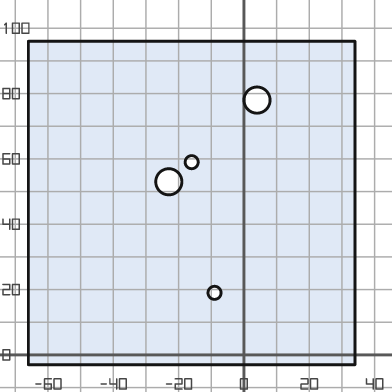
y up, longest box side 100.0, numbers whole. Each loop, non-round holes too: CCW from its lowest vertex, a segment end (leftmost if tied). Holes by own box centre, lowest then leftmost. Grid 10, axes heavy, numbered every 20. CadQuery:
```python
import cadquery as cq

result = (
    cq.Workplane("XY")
    .moveTo(-66.0, -3.0)
    .lineTo(34.0, -3.0)
    .lineTo(34.0, 96.0)
    .lineTo(-66.0, 96.0)
    .close()
    .moveTo(-9.0, 19.0)
    .circle(2.0)
    .moveTo(-23.0, 53.0)
    .circle(4.0)
    .moveTo(-16.0, 59.0)
    .circle(2.0)
    .moveTo(4.0, 78.0)
    .circle(4.0)
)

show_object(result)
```